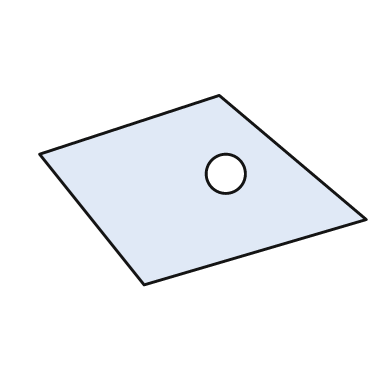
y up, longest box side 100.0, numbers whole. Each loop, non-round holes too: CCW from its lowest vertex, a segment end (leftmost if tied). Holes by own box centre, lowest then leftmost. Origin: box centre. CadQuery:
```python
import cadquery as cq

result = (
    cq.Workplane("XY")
    .moveTo(-18.0, -29.0)
    .lineTo(50.0, -9.0)
    .lineTo(5.0, 29.0)
    .lineTo(-50.0, 11.0)
    .close()
    .moveTo(7.0, 5.0)
    .circle(6.0)
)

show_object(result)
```